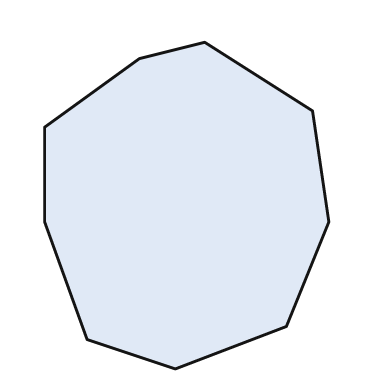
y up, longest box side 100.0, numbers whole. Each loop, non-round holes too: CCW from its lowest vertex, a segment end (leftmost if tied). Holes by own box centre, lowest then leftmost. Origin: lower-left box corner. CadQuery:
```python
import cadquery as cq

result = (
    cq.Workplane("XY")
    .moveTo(40.0, 0.0)
    .lineTo(74.0, 13.0)
    .lineTo(87.0, 45.0)
    .lineTo(82.0, 79.0)
    .lineTo(49.0, 100.0)
    .lineTo(29.0, 95.0)
    .lineTo(0.0, 74.0)
    .lineTo(0.0, 45.0)
    .lineTo(13.0, 9.0)
    .close()
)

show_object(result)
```